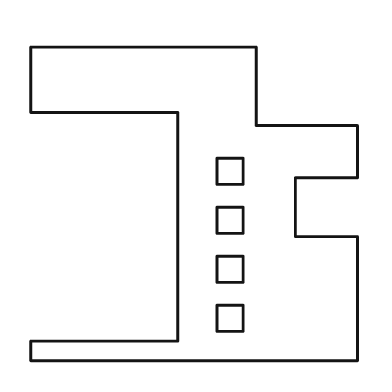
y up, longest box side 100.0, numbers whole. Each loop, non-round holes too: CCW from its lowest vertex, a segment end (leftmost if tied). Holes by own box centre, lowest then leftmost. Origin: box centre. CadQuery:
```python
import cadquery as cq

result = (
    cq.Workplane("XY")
    .moveTo(-50.0, -48.0)
    .lineTo(50.0, -48.0)
    .lineTo(50.0, -10.0)
    .lineTo(31.0, -10.0)
    .lineTo(31.0, 8.0)
    .lineTo(50.0, 8.0)
    .lineTo(50.0, 24.0)
    .lineTo(19.0, 24.0)
    .lineTo(19.0, 48.0)
    .lineTo(-50.0, 48.0)
    .lineTo(-50.0, 28.0)
    .lineTo(-5.0, 28.0)
    .lineTo(-5.0, -42.0)
    .lineTo(-50.0, -42.0)
    .close()
    .moveTo(7.0, -39.0)
    .lineTo(15.0, -39.0)
    .lineTo(15.0, -31.0)
    .lineTo(7.0, -31.0)
    .close()
    .moveTo(7.0, -24.0)
    .lineTo(15.0, -24.0)
    .lineTo(15.0, -16.0)
    .lineTo(7.0, -16.0)
    .close()
    .moveTo(7.0, -9.0)
    .lineTo(15.0, -9.0)
    .lineTo(15.0, -1.0)
    .lineTo(7.0, -1.0)
    .close()
    .moveTo(7.0, 6.0)
    .lineTo(15.0, 6.0)
    .lineTo(15.0, 14.0)
    .lineTo(7.0, 14.0)
    .close()
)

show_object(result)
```